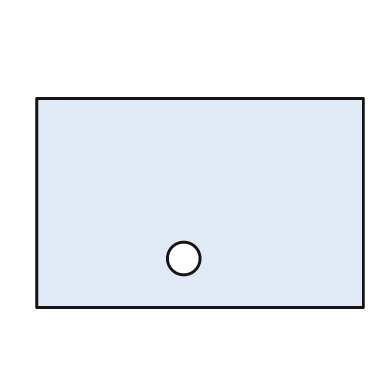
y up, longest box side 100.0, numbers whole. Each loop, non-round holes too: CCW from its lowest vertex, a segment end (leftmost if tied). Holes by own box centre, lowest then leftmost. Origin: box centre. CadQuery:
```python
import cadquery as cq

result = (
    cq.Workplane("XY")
    .moveTo(-50.0, -32.0)
    .lineTo(50.0, -32.0)
    .lineTo(50.0, 32.0)
    .lineTo(-50.0, 32.0)
    .close()
    .moveTo(-5.0, -17.0)
    .circle(5.0)
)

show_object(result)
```